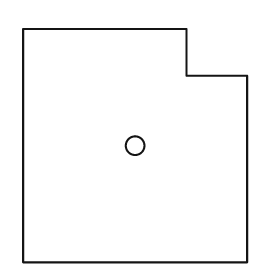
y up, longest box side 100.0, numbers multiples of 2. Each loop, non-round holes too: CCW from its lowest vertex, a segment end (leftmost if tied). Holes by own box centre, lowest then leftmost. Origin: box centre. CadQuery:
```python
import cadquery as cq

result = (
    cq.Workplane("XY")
    .moveTo(-48.0, -50.0)
    .lineTo(48.0, -50.0)
    .lineTo(48.0, 30.0)
    .lineTo(22.0, 30.0)
    .lineTo(22.0, 50.0)
    .lineTo(-48.0, 50.0)
    .close()
    .moveTo(0.0, 0.0)
    .circle(4.0)
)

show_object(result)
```